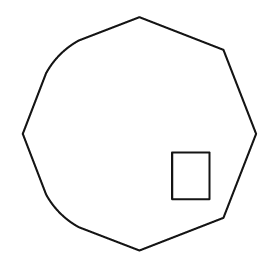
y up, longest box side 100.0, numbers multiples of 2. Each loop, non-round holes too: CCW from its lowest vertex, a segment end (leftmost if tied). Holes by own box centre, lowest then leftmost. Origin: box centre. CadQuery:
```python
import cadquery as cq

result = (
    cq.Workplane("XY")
    .moveTo(0.0, -50.0)
    .lineTo(36.0, -36.0)
    .lineTo(50.0, 0.0)
    .lineTo(36.0, 36.0)
    .lineTo(0.0, 50.0)
    .lineTo(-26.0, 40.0)
    .threePointArc((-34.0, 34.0), (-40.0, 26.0))
    .lineTo(-50.0, 0.0)
    .lineTo(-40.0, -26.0)
    .threePointArc((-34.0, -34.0), (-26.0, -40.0))
    .close()
    .moveTo(14.0, -28.0)
    .lineTo(30.0, -28.0)
    .lineTo(30.0, -8.0)
    .lineTo(14.0, -8.0)
    .close()
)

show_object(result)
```